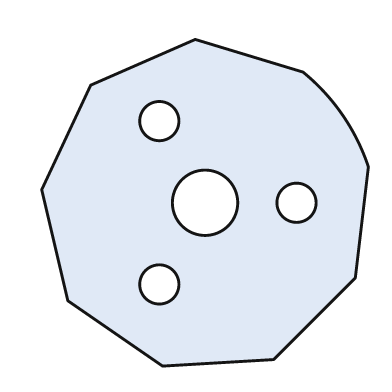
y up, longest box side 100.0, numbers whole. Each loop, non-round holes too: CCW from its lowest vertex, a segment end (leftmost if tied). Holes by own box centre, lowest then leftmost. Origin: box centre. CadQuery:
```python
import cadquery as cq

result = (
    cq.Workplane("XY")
    .moveTo(-13.0, -50.0)
    .lineTo(21.0, -48.0)
    .lineTo(46.0, -23.0)
    .lineTo(50.0, 11.0)
    .threePointArc((42.0, 27.0), (30.0, 40.0))
    .lineTo(-3.0, 50.0)
    .lineTo(-35.0, 36.0)
    .lineTo(-50.0, 4.0)
    .lineTo(-42.0, -30.0)
    .close()
    .moveTo(-14.0, -25.0)
    .circle(6.0)
    .moveTo(0.0, 0.0)
    .circle(10.0)
    .moveTo(28.0, 0.0)
    .circle(6.0)
    .moveTo(-14.0, 25.0)
    .circle(6.0)
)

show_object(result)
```